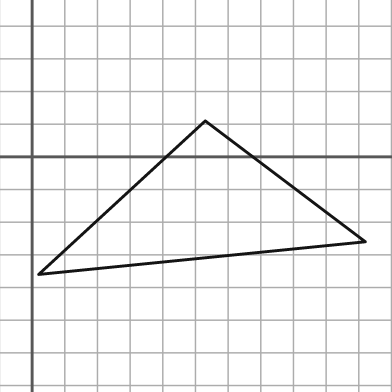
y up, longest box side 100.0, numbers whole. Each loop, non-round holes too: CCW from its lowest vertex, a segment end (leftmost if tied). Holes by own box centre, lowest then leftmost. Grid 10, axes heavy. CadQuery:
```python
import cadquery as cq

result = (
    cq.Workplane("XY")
    .moveTo(2.0, -36.0)
    .lineTo(102.0, -26.0)
    .lineTo(53.0, 11.0)
    .close()
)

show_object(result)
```